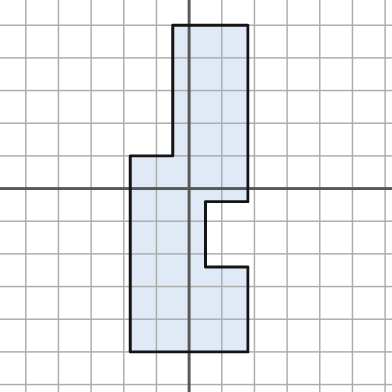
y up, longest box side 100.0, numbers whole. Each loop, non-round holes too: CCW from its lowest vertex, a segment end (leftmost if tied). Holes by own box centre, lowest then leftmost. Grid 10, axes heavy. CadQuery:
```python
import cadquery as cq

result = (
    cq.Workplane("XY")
    .moveTo(-18.0, -50.0)
    .lineTo(18.0, -50.0)
    .lineTo(18.0, -24.0)
    .lineTo(5.0, -24.0)
    .lineTo(5.0, -4.0)
    .lineTo(18.0, -4.0)
    .lineTo(18.0, 50.0)
    .lineTo(-5.0, 50.0)
    .lineTo(-5.0, 10.0)
    .lineTo(-18.0, 10.0)
    .close()
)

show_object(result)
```